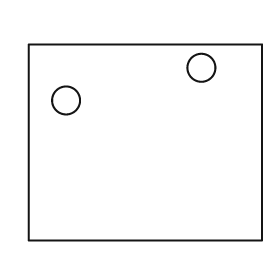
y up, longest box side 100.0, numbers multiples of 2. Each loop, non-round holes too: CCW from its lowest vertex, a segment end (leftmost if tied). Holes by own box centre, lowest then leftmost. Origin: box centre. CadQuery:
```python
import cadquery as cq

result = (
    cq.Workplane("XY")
    .moveTo(-50.0, -42.0)
    .lineTo(50.0, -42.0)
    .lineTo(50.0, 42.0)
    .lineTo(-50.0, 42.0)
    .close()
    .moveTo(-34.0, 18.0)
    .circle(6.0)
    .moveTo(24.0, 32.0)
    .circle(6.0)
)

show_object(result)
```